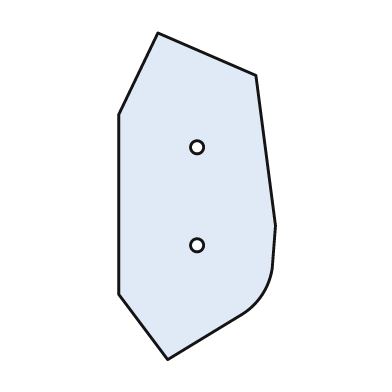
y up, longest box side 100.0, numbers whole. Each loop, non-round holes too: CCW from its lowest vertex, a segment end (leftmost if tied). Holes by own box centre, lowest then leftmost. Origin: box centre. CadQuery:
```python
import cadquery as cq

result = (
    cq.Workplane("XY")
    .moveTo(-9.0, -50.0)
    .lineTo(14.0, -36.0)
    .threePointArc((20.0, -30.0), (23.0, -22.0))
    .lineTo(24.0, -9.0)
    .lineTo(18.0, 37.0)
    .lineTo(-12.0, 50.0)
    .lineTo(-24.0, 25.0)
    .lineTo(-24.0, -30.0)
    .close()
    .moveTo(0.0, -15.0)
    .circle(2.0)
    .moveTo(0.0, 15.0)
    .circle(2.0)
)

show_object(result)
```